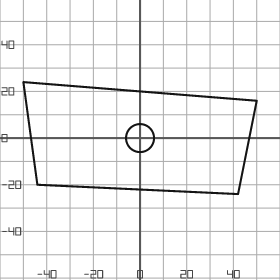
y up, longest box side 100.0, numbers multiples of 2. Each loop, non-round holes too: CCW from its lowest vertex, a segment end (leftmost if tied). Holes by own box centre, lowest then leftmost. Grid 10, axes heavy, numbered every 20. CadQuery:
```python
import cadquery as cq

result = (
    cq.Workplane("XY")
    .moveTo(42.0, -24.0)
    .lineTo(50.0, 16.0)
    .lineTo(-50.0, 24.0)
    .lineTo(-44.0, -20.0)
    .close()
    .moveTo(0.0, 0.0)
    .circle(6.0)
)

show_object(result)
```